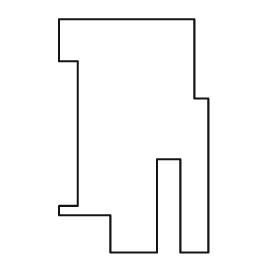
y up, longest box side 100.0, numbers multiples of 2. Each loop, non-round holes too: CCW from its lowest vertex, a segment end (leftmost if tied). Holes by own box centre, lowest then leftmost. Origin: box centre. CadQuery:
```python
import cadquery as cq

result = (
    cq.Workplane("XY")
    .moveTo(-10.0, -50.0)
    .lineTo(10.0, -50.0)
    .lineTo(10.0, -10.0)
    .lineTo(20.0, -10.0)
    .lineTo(20.0, -50.0)
    .lineTo(32.0, -50.0)
    .lineTo(32.0, 16.0)
    .lineTo(26.0, 16.0)
    .lineTo(26.0, 50.0)
    .lineTo(-32.0, 50.0)
    .lineTo(-32.0, 32.0)
    .lineTo(-24.0, 32.0)
    .lineTo(-24.0, -30.0)
    .lineTo(-32.0, -30.0)
    .lineTo(-32.0, -34.0)
    .lineTo(-10.0, -34.0)
    .close()
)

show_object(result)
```